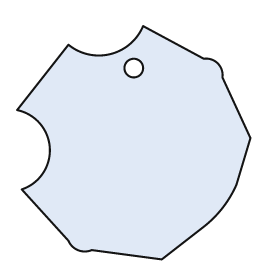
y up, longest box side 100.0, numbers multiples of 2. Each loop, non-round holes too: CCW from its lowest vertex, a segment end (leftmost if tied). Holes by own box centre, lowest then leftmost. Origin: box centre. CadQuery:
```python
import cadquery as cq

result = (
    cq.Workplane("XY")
    .moveTo(12.0, -50.0)
    .lineTo(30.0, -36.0)
    .threePointArc((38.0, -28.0), (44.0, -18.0))
    .lineTo(50.0, 2.0)
    .lineTo(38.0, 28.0)
    .threePointArc((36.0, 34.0), (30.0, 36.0))
    .lineTo(4.0, 50.0)
    .threePointArc((-10.0, 38.0), (-28.0, 42.0))
    .lineTo(-50.0, 14.0)
    .threePointArc((-36.0, -2.0), (-48.0, -20.0))
    .lineTo(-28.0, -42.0)
    .threePointArc((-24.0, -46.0), (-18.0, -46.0))
    .close()
    .moveTo(0.0, 32.0)
    .circle(4.0)
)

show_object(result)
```